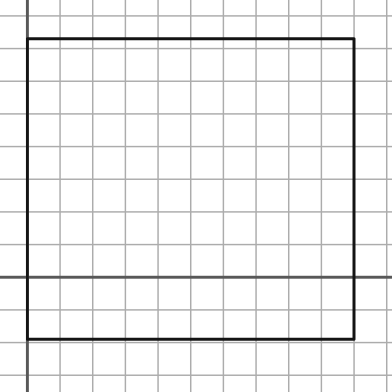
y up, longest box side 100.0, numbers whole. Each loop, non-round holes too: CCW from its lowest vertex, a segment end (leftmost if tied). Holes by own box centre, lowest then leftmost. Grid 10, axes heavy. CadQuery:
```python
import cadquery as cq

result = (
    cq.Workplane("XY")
    .moveTo(0.0, -19.0)
    .lineTo(100.0, -19.0)
    .lineTo(100.0, 73.0)
    .lineTo(0.0, 73.0)
    .close()
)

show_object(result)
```